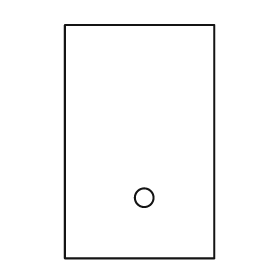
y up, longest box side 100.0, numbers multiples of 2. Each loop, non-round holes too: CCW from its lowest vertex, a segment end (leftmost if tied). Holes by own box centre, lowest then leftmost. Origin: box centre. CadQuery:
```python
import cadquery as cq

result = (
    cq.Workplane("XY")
    .moveTo(-32.0, -50.0)
    .lineTo(32.0, -50.0)
    .lineTo(32.0, 50.0)
    .lineTo(-32.0, 50.0)
    .close()
    .moveTo(2.0, -24.0)
    .circle(4.0)
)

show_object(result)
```